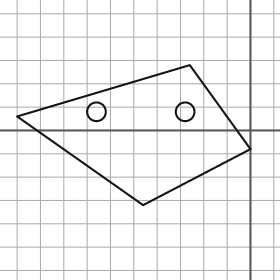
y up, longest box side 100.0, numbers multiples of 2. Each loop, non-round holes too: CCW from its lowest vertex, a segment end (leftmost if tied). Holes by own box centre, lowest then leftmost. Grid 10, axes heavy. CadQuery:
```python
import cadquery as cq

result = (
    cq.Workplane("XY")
    .moveTo(-46.0, -32.0)
    .lineTo(0.0, -8.0)
    .lineTo(-26.0, 28.0)
    .lineTo(-100.0, 6.0)
    .close()
    .moveTo(-66.0, 8.0)
    .circle(4.0)
    .moveTo(-28.0, 8.0)
    .circle(4.0)
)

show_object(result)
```